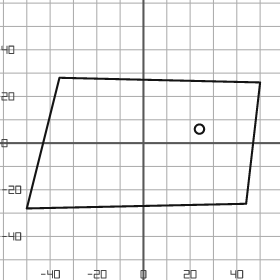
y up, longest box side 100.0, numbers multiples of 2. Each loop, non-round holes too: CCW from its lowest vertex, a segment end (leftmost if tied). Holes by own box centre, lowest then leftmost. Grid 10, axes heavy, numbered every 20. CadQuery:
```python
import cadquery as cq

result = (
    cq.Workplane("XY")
    .moveTo(-50.0, -28.0)
    .lineTo(44.0, -26.0)
    .lineTo(50.0, 26.0)
    .lineTo(-36.0, 28.0)
    .close()
    .moveTo(24.0, 6.0)
    .circle(2.0)
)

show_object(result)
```